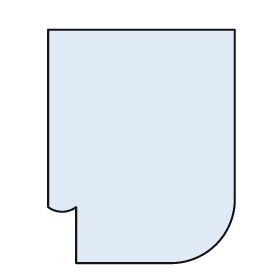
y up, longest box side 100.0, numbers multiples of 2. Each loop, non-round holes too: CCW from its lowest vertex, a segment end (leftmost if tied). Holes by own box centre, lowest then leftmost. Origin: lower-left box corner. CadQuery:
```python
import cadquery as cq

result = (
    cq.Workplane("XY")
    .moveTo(12.0, 0.0)
    .lineTo(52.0, 0.0)
    .threePointArc((72.0, 8.0), (80.0, 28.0))
    .lineTo(80.0, 100.0)
    .lineTo(0.0, 100.0)
    .lineTo(0.0, 24.0)
    .threePointArc((6.0, 22.0), (12.0, 24.0))
    .close()
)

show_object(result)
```